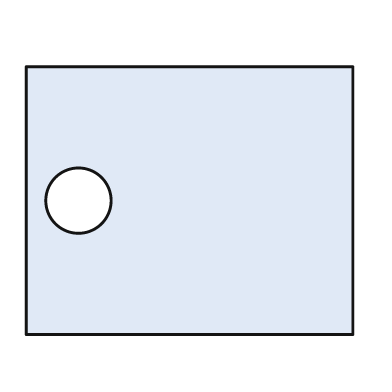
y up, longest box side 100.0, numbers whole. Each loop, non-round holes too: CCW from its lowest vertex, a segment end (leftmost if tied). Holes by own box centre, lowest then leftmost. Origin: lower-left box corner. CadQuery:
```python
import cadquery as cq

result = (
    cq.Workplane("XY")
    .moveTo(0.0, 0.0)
    .lineTo(100.0, 0.0)
    .lineTo(100.0, 82.0)
    .lineTo(0.0, 82.0)
    .close()
    .moveTo(16.0, 41.0)
    .circle(10.0)
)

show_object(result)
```